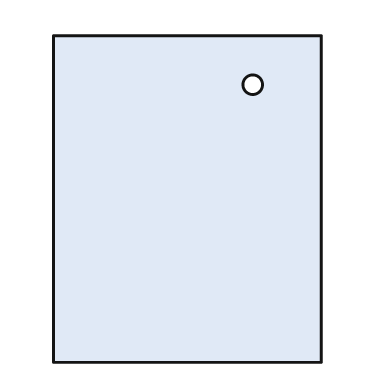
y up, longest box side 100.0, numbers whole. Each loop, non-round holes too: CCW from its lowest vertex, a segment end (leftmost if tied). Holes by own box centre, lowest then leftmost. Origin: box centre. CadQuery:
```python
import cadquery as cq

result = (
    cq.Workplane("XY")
    .moveTo(-41.0, -50.0)
    .lineTo(41.0, -50.0)
    .lineTo(41.0, 50.0)
    .lineTo(-41.0, 50.0)
    .close()
    .moveTo(20.0, 35.0)
    .circle(3.0)
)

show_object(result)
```